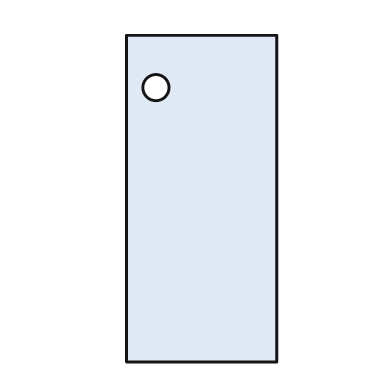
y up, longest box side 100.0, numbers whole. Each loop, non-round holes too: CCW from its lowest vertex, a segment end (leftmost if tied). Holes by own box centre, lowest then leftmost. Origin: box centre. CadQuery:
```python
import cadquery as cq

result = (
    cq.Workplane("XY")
    .moveTo(-23.0, -50.0)
    .lineTo(23.0, -50.0)
    .lineTo(23.0, 50.0)
    .lineTo(-23.0, 50.0)
    .close()
    .moveTo(-14.0, 34.0)
    .circle(4.0)
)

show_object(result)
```